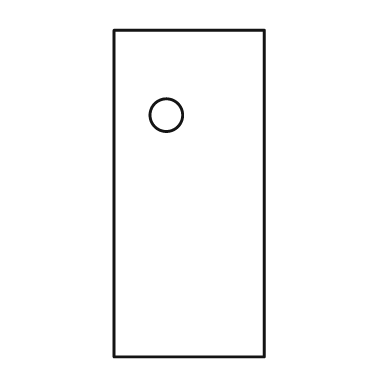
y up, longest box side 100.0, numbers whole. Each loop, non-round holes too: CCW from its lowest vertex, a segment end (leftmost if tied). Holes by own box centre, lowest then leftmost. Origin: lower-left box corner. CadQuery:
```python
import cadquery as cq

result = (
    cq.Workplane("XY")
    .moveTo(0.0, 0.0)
    .lineTo(46.0, 0.0)
    .lineTo(46.0, 100.0)
    .lineTo(0.0, 100.0)
    .close()
    .moveTo(16.0, 74.0)
    .circle(5.0)
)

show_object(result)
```